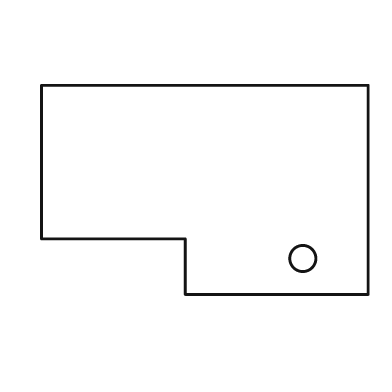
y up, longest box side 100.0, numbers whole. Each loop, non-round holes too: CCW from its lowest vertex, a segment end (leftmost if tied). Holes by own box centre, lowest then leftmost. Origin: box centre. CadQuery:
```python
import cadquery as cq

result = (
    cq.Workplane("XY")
    .moveTo(-6.0, -32.0)
    .lineTo(50.0, -32.0)
    .lineTo(50.0, 32.0)
    .lineTo(-50.0, 32.0)
    .lineTo(-50.0, -15.0)
    .lineTo(-6.0, -15.0)
    .close()
    .moveTo(30.0, -21.0)
    .circle(4.0)
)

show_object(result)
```